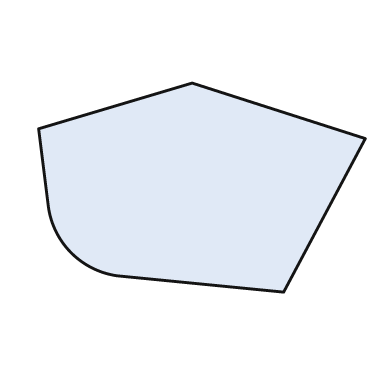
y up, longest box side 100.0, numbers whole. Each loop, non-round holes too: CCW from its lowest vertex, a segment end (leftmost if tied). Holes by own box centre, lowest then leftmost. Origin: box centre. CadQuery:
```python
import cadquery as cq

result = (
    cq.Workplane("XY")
    .moveTo(25.0, -32.0)
    .lineTo(50.0, 15.0)
    .lineTo(-3.0, 32.0)
    .lineTo(-50.0, 18.0)
    .lineTo(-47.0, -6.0)
    .threePointArc((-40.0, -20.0), (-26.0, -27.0))
    .close()
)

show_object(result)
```